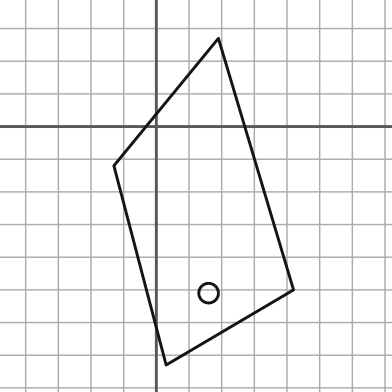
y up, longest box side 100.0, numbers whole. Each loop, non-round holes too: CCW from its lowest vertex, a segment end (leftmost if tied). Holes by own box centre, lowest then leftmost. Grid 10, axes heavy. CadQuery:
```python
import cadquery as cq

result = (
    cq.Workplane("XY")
    .moveTo(3.0, -73.0)
    .lineTo(42.0, -50.0)
    .lineTo(19.0, 27.0)
    .lineTo(-13.0, -12.0)
    .close()
    .moveTo(16.0, -51.0)
    .circle(3.0)
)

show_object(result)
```